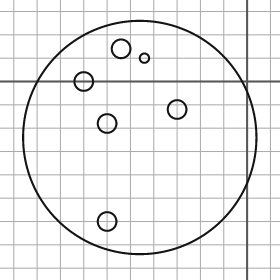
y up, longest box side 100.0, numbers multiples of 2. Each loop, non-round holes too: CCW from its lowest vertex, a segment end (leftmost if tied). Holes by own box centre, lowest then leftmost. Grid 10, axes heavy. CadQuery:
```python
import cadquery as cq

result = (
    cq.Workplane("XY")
    .moveTo(-46.0, -24.0)
    .circle(50.0)
    .moveTo(-60.0, -60.0)
    .circle(4.0)
    .moveTo(-60.0, -18.0)
    .circle(4.0)
    .moveTo(-30.0, -12.0)
    .circle(4.0)
    .moveTo(-70.0, 0.0)
    .circle(4.0)
    .moveTo(-44.0, 10.0)
    .circle(2.0)
    .moveTo(-54.0, 14.0)
    .circle(4.0)
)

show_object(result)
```